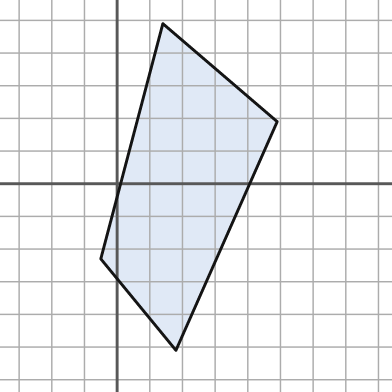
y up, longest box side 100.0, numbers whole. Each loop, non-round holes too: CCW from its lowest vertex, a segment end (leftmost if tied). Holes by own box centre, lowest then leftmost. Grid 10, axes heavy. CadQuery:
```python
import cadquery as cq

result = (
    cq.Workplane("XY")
    .moveTo(18.0, -51.0)
    .lineTo(49.0, 19.0)
    .lineTo(14.0, 49.0)
    .lineTo(-5.0, -23.0)
    .close()
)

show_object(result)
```